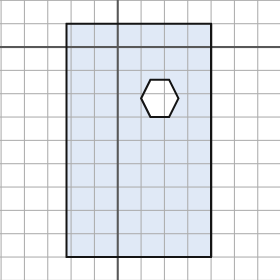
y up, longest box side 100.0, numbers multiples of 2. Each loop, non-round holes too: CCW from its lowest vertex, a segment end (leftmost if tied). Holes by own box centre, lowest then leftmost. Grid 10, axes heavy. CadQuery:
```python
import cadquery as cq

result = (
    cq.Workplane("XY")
    .moveTo(-22.0, -90.0)
    .lineTo(40.0, -90.0)
    .lineTo(40.0, 10.0)
    .lineTo(-22.0, 10.0)
    .close()
    .moveTo(14.0, -30.0)
    .lineTo(22.0, -30.0)
    .lineTo(26.0, -22.0)
    .lineTo(22.0, -14.0)
    .lineTo(14.0, -14.0)
    .lineTo(10.0, -22.0)
    .close()
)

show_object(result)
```